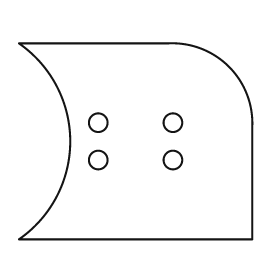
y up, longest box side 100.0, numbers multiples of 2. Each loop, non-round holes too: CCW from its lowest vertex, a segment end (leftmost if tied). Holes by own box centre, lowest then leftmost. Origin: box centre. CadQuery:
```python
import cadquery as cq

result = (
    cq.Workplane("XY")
    .moveTo(-50.0, -42.0)
    .lineTo(50.0, -42.0)
    .lineTo(50.0, 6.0)
    .threePointArc((40.0, 32.0), (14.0, 42.0))
    .lineTo(-50.0, 42.0)
    .threePointArc((-28.0, 0.0), (-50.0, -42.0))
    .close()
    .moveTo(-16.0, -8.0)
    .circle(4.0)
    .moveTo(16.0, -8.0)
    .circle(4.0)
    .moveTo(-16.0, 8.0)
    .circle(4.0)
    .moveTo(16.0, 8.0)
    .circle(4.0)
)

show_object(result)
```